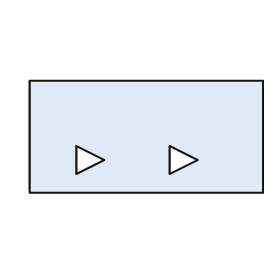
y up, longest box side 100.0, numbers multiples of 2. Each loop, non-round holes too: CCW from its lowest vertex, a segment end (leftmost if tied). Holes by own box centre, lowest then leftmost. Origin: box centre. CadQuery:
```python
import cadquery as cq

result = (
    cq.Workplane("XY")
    .moveTo(-50.0, -24.0)
    .lineTo(50.0, -24.0)
    .lineTo(50.0, 24.0)
    .lineTo(-50.0, 24.0)
    .close()
    .moveTo(-30.0, -16.0)
    .lineTo(-18.0, -10.0)
    .lineTo(-30.0, -4.0)
    .close()
    .moveTo(10.0, -16.0)
    .lineTo(22.0, -10.0)
    .lineTo(10.0, -4.0)
    .close()
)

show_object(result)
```